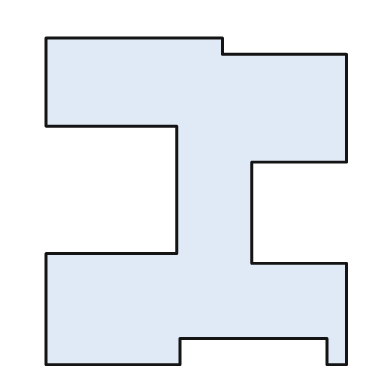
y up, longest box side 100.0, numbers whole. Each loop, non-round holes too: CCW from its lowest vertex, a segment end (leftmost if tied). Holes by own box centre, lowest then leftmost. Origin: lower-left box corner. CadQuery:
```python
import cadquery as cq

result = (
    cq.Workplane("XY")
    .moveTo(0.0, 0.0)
    .lineTo(41.0, 0.0)
    .lineTo(41.0, 8.0)
    .lineTo(86.0, 8.0)
    .lineTo(86.0, 0.0)
    .lineTo(92.0, 0.0)
    .lineTo(92.0, 31.0)
    .lineTo(63.0, 31.0)
    .lineTo(63.0, 62.0)
    .lineTo(92.0, 62.0)
    .lineTo(92.0, 95.0)
    .lineTo(54.0, 95.0)
    .lineTo(54.0, 100.0)
    .lineTo(0.0, 100.0)
    .lineTo(0.0, 73.0)
    .lineTo(40.0, 73.0)
    .lineTo(40.0, 34.0)
    .lineTo(0.0, 34.0)
    .close()
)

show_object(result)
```